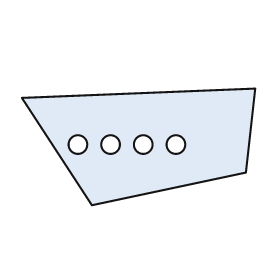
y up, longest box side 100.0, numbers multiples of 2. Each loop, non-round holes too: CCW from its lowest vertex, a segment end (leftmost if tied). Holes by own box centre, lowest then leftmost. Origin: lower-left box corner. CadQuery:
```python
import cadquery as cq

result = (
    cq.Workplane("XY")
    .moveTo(30.0, 0.0)
    .lineTo(96.0, 14.0)
    .lineTo(100.0, 50.0)
    .lineTo(0.0, 46.0)
    .close()
    .moveTo(24.0, 26.0)
    .circle(4.0)
    .moveTo(38.0, 26.0)
    .circle(4.0)
    .moveTo(52.0, 26.0)
    .circle(4.0)
    .moveTo(66.0, 26.0)
    .circle(4.0)
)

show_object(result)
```